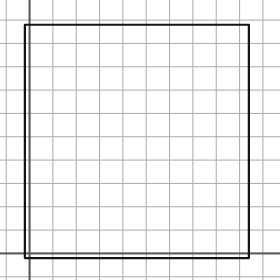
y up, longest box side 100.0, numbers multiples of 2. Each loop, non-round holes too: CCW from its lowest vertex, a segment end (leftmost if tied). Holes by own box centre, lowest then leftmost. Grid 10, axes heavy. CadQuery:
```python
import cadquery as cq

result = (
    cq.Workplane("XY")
    .moveTo(-2.0, -2.0)
    .lineTo(94.0, -2.0)
    .lineTo(94.0, 98.0)
    .lineTo(-2.0, 98.0)
    .close()
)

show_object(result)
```